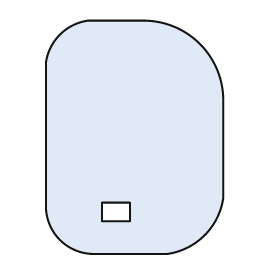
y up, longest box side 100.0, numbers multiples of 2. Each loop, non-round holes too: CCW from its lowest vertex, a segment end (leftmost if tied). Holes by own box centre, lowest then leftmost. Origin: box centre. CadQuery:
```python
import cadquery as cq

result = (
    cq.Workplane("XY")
    .moveTo(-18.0, -50.0)
    .lineTo(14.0, -50.0)
    .threePointArc((30.0, -42.0), (38.0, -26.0))
    .lineTo(38.0, 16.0)
    .threePointArc((28.0, 40.0), (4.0, 50.0))
    .lineTo(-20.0, 50.0)
    .threePointArc((-32.0, 44.0), (-38.0, 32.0))
    .lineTo(-38.0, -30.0)
    .threePointArc((-32.0, -44.0), (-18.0, -50.0))
    .close()
    .moveTo(-14.0, -36.0)
    .lineTo(-2.0, -36.0)
    .lineTo(-2.0, -28.0)
    .lineTo(-14.0, -28.0)
    .close()
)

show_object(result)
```